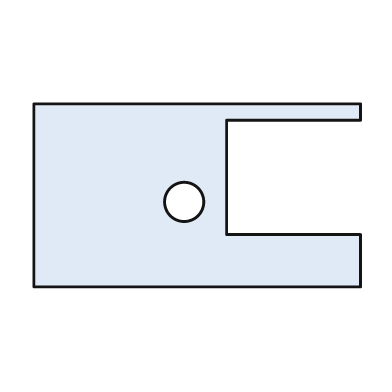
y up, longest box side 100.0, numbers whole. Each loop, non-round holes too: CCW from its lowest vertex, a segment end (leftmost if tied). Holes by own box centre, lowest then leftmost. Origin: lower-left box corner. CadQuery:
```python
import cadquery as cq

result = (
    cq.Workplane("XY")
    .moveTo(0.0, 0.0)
    .lineTo(100.0, 0.0)
    .lineTo(100.0, 16.0)
    .lineTo(59.0, 16.0)
    .lineTo(59.0, 51.0)
    .lineTo(100.0, 51.0)
    .lineTo(100.0, 56.0)
    .lineTo(0.0, 56.0)
    .close()
    .moveTo(46.0, 26.0)
    .circle(6.0)
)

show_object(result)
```